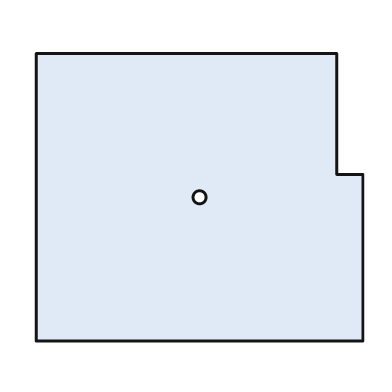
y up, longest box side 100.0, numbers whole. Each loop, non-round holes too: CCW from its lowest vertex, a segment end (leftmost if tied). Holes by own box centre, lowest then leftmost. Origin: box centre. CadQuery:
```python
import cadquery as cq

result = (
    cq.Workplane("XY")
    .moveTo(-50.0, -44.0)
    .lineTo(50.0, -44.0)
    .lineTo(50.0, 7.0)
    .lineTo(42.0, 7.0)
    .lineTo(42.0, 44.0)
    .lineTo(-50.0, 44.0)
    .close()
    .moveTo(0.0, 0.0)
    .circle(2.0)
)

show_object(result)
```